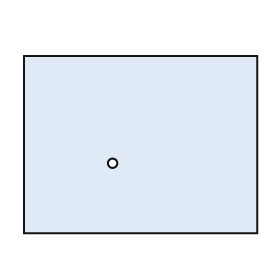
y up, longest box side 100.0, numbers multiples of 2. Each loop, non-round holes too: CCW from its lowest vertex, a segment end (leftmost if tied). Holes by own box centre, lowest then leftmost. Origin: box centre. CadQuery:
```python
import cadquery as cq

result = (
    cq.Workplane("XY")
    .moveTo(-50.0, -38.0)
    .lineTo(50.0, -38.0)
    .lineTo(50.0, 38.0)
    .lineTo(-50.0, 38.0)
    .close()
    .moveTo(-12.0, -8.0)
    .circle(2.0)
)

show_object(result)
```